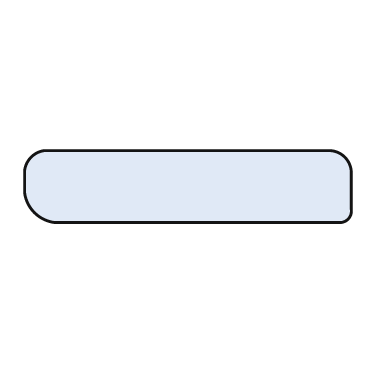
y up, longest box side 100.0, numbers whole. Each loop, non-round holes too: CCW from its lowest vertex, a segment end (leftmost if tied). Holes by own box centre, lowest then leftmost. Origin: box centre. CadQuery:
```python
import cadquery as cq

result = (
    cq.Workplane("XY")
    .moveTo(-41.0, -11.0)
    .lineTo(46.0, -11.0)
    .threePointArc((49.0, -10.0), (50.0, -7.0))
    .lineTo(50.0, 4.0)
    .threePointArc((48.0, 9.0), (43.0, 11.0))
    .lineTo(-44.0, 11.0)
    .threePointArc((-48.0, 9.0), (-50.0, 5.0))
    .lineTo(-50.0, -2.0)
    .threePointArc((-47.0, -8.0), (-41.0, -11.0))
    .close()
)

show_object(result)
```